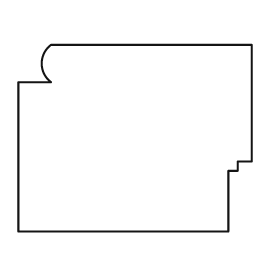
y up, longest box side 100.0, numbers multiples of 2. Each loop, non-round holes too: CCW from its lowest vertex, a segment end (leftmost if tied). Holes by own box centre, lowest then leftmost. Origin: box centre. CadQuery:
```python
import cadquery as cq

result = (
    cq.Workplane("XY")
    .moveTo(-50.0, -40.0)
    .lineTo(40.0, -40.0)
    .lineTo(40.0, -14.0)
    .lineTo(44.0, -14.0)
    .lineTo(44.0, -10.0)
    .lineTo(50.0, -10.0)
    .lineTo(50.0, 40.0)
    .lineTo(-36.0, 40.0)
    .threePointArc((-40.0, 32.0), (-36.0, 24.0))
    .lineTo(-50.0, 24.0)
    .close()
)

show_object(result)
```